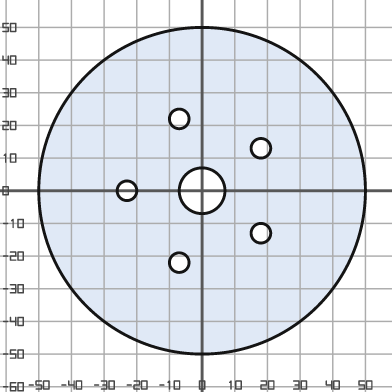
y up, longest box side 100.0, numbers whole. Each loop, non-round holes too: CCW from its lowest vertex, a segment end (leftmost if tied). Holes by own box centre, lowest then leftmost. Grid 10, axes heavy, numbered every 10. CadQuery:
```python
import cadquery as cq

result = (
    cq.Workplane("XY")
    .moveTo(0.0, 0.0)
    .circle(50.0)
    .moveTo(-7.0, -22.0)
    .circle(3.0)
    .moveTo(18.0, -13.0)
    .circle(3.0)
    .moveTo(-23.0, 0.0)
    .circle(3.0)
    .moveTo(0.0, 0.0)
    .circle(7.0)
    .moveTo(18.0, 13.0)
    .circle(3.0)
    .moveTo(-7.0, 22.0)
    .circle(3.0)
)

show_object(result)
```